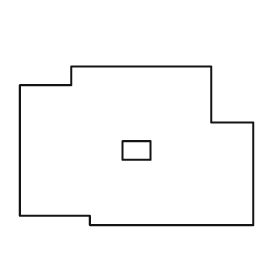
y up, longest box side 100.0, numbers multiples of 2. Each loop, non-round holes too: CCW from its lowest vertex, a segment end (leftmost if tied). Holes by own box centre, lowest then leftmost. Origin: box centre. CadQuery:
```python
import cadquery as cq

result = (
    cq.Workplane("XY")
    .moveTo(-20.0, -34.0)
    .lineTo(50.0, -34.0)
    .lineTo(50.0, 10.0)
    .lineTo(32.0, 10.0)
    .lineTo(32.0, 34.0)
    .lineTo(-28.0, 34.0)
    .lineTo(-28.0, 26.0)
    .lineTo(-50.0, 26.0)
    .lineTo(-50.0, -30.0)
    .lineTo(-20.0, -30.0)
    .close()
    .moveTo(-6.0, -6.0)
    .lineTo(6.0, -6.0)
    .lineTo(6.0, 2.0)
    .lineTo(-6.0, 2.0)
    .close()
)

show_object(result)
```